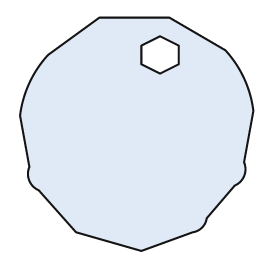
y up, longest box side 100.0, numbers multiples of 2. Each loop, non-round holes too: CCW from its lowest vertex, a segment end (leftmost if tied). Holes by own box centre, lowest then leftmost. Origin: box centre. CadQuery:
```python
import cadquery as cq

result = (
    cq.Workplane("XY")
    .moveTo(2.0, -50.0)
    .lineTo(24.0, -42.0)
    .threePointArc((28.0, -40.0), (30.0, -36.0))
    .lineTo(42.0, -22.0)
    .threePointArc((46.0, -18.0), (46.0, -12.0))
    .lineTo(50.0, 10.0)
    .threePointArc((46.0, 24.0), (38.0, 36.0))
    .lineTo(14.0, 50.0)
    .lineTo(-16.0, 50.0)
    .lineTo(-38.0, 34.0)
    .threePointArc((-46.0, 22.0), (-50.0, 8.0))
    .lineTo(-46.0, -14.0)
    .threePointArc((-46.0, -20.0), (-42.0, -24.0))
    .lineTo(-26.0, -42.0)
    .close()
    .moveTo(10.0, 26.0)
    .lineTo(18.0, 30.0)
    .lineTo(18.0, 38.0)
    .lineTo(10.0, 42.0)
    .lineTo(2.0, 38.0)
    .lineTo(2.0, 30.0)
    .close()
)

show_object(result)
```